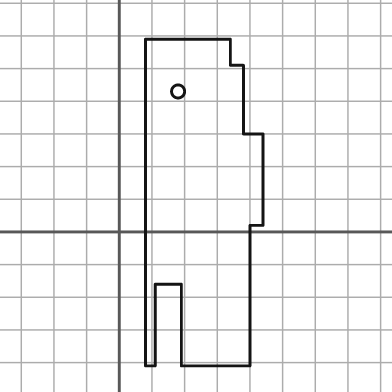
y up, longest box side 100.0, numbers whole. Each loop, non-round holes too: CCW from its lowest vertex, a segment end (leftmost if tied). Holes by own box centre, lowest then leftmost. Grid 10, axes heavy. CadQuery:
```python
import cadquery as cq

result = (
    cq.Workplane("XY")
    .moveTo(8.0, -41.0)
    .lineTo(11.0, -41.0)
    .lineTo(11.0, -16.0)
    .lineTo(19.0, -16.0)
    .lineTo(19.0, -41.0)
    .lineTo(40.0, -41.0)
    .lineTo(40.0, 2.0)
    .lineTo(44.0, 2.0)
    .lineTo(44.0, 30.0)
    .lineTo(38.0, 30.0)
    .lineTo(38.0, 51.0)
    .lineTo(34.0, 51.0)
    .lineTo(34.0, 59.0)
    .lineTo(8.0, 59.0)
    .close()
    .moveTo(18.0, 43.0)
    .circle(2.0)
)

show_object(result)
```